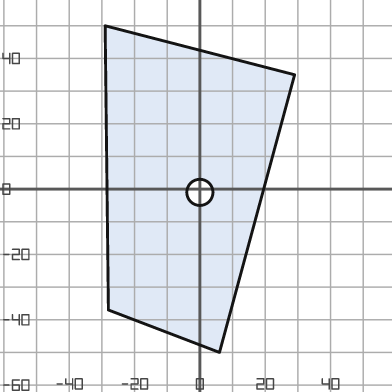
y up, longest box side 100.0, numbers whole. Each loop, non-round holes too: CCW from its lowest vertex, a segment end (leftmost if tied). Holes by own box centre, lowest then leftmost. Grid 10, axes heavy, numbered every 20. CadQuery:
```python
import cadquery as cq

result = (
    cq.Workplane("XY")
    .moveTo(6.0, -50.0)
    .lineTo(29.0, 35.0)
    .lineTo(-29.0, 50.0)
    .lineTo(-28.0, -37.0)
    .close()
    .moveTo(0.0, -1.0)
    .circle(4.0)
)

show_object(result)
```